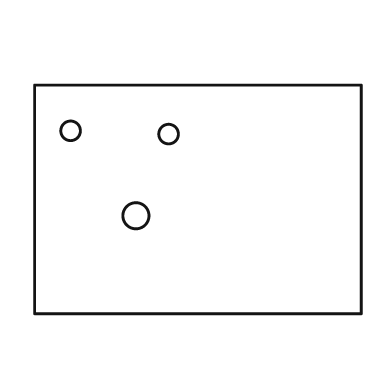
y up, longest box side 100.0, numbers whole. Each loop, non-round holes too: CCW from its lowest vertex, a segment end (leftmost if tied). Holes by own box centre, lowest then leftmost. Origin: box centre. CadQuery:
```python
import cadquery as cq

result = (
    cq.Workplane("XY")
    .moveTo(-50.0, -35.0)
    .lineTo(50.0, -35.0)
    .lineTo(50.0, 35.0)
    .lineTo(-50.0, 35.0)
    .close()
    .moveTo(-19.0, -5.0)
    .circle(4.0)
    .moveTo(-9.0, 20.0)
    .circle(3.0)
    .moveTo(-39.0, 21.0)
    .circle(3.0)
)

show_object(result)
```